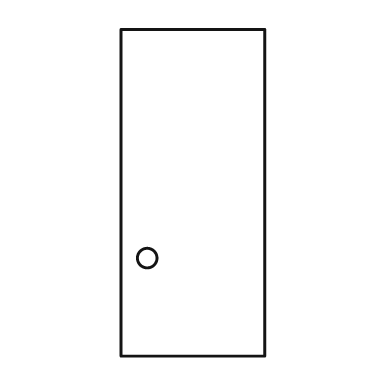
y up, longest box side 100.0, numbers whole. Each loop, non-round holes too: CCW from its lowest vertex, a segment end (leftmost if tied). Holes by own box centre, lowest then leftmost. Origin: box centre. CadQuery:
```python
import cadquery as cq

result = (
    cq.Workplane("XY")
    .moveTo(-22.0, -50.0)
    .lineTo(22.0, -50.0)
    .lineTo(22.0, 50.0)
    .lineTo(-22.0, 50.0)
    .close()
    .moveTo(-14.0, -20.0)
    .circle(3.0)
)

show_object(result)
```